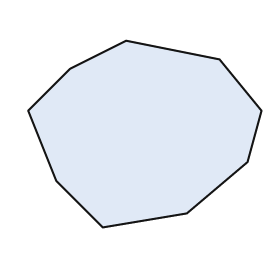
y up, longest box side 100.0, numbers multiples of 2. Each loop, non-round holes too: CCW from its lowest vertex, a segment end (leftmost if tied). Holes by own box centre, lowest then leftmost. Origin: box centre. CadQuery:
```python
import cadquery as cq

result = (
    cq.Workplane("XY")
    .moveTo(-18.0, -40.0)
    .lineTo(18.0, -34.0)
    .lineTo(44.0, -12.0)
    .lineTo(50.0, 10.0)
    .lineTo(32.0, 32.0)
    .lineTo(-8.0, 40.0)
    .lineTo(-32.0, 28.0)
    .lineTo(-50.0, 10.0)
    .lineTo(-38.0, -20.0)
    .close()
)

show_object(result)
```